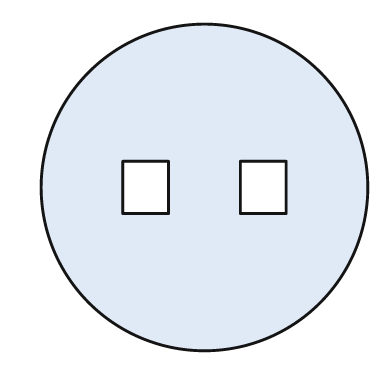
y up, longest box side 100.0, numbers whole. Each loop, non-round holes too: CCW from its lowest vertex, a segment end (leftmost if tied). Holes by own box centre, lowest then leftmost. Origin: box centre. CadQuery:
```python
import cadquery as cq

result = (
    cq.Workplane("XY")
    .moveTo(0.0, 0.0)
    .circle(50.0)
    .moveTo(-25.0, -8.0)
    .lineTo(-11.0, -8.0)
    .lineTo(-11.0, 8.0)
    .lineTo(-25.0, 8.0)
    .close()
    .moveTo(11.0, -8.0)
    .lineTo(25.0, -8.0)
    .lineTo(25.0, 8.0)
    .lineTo(11.0, 8.0)
    .close()
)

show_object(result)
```